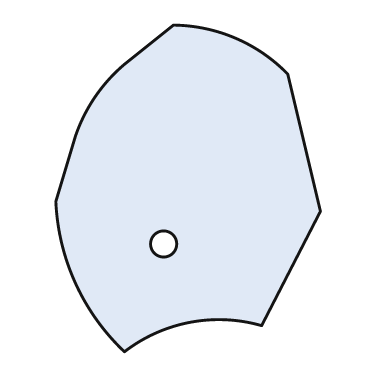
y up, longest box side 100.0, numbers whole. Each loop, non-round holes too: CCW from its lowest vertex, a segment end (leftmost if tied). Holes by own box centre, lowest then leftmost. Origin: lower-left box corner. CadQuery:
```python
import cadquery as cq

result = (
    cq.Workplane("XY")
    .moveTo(21.0, 0.0)
    .threePointArc((41.0, 9.0), (63.0, 8.0))
    .lineTo(81.0, 43.0)
    .lineTo(71.0, 85.0)
    .threePointArc((55.0, 96.0), (36.0, 100.0))
    .lineTo(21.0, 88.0)
    .threePointArc((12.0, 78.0), (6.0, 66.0))
    .lineTo(0.0, 46.0)
    .threePointArc((6.0, 21.0), (21.0, 0.0))
    .close()
    .moveTo(33.0, 33.0)
    .circle(4.0)
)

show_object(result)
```